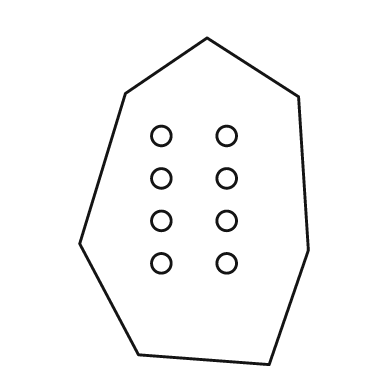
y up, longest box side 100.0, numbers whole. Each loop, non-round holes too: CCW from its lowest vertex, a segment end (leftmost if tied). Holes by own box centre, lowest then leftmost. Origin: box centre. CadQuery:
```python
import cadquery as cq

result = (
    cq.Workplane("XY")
    .moveTo(23.0, -50.0)
    .lineTo(35.0, -15.0)
    .lineTo(32.0, 32.0)
    .lineTo(4.0, 50.0)
    .lineTo(-21.0, 33.0)
    .lineTo(-35.0, -13.0)
    .lineTo(-17.0, -47.0)
    .close()
    .moveTo(-10.0, -19.0)
    .circle(3.0)
    .moveTo(10.0, -19.0)
    .circle(3.0)
    .moveTo(-10.0, -6.0)
    .circle(3.0)
    .moveTo(10.0, -6.0)
    .circle(3.0)
    .moveTo(-10.0, 7.0)
    .circle(3.0)
    .moveTo(10.0, 7.0)
    .circle(3.0)
    .moveTo(-10.0, 20.0)
    .circle(3.0)
    .moveTo(10.0, 20.0)
    .circle(3.0)
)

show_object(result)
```